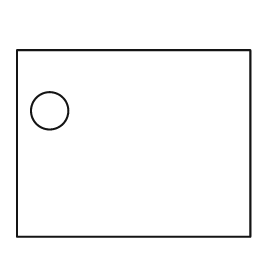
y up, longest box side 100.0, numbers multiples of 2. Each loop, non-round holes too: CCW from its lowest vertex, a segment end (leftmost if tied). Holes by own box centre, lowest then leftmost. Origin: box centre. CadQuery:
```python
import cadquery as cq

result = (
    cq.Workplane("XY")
    .moveTo(-50.0, -40.0)
    .lineTo(50.0, -40.0)
    .lineTo(50.0, 40.0)
    .lineTo(-50.0, 40.0)
    .close()
    .moveTo(-36.0, 14.0)
    .circle(8.0)
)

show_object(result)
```